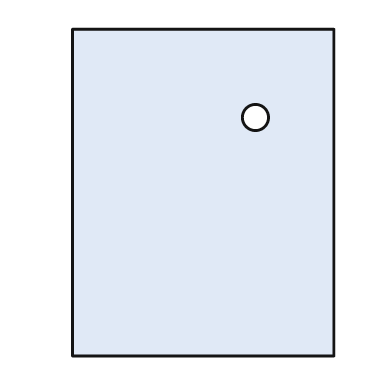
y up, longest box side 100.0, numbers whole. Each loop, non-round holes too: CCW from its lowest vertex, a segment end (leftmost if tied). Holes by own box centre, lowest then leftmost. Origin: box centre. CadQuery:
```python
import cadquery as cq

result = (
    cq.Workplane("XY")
    .moveTo(-40.0, -50.0)
    .lineTo(40.0, -50.0)
    .lineTo(40.0, 50.0)
    .lineTo(-40.0, 50.0)
    .close()
    .moveTo(16.0, 23.0)
    .circle(4.0)
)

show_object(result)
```